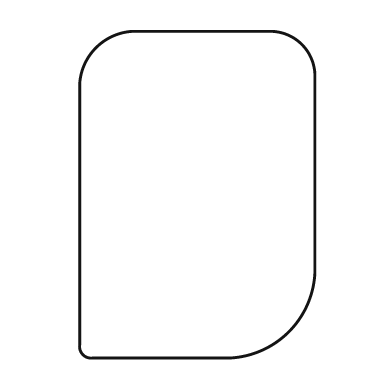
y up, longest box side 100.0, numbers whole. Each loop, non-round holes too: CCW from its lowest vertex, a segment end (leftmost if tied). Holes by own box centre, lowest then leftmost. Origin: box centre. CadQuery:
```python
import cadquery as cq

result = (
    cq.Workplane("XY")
    .moveTo(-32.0, -50.0)
    .lineTo(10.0, -50.0)
    .threePointArc((28.0, -42.0), (36.0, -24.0))
    .lineTo(36.0, 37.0)
    .threePointArc((32.0, 46.0), (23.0, 50.0))
    .lineTo(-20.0, 50.0)
    .threePointArc((-31.0, 45.0), (-36.0, 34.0))
    .lineTo(-36.0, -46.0)
    .threePointArc((-35.0, -49.0), (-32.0, -50.0))
    .close()
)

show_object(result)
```